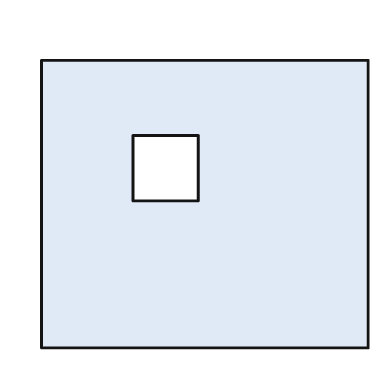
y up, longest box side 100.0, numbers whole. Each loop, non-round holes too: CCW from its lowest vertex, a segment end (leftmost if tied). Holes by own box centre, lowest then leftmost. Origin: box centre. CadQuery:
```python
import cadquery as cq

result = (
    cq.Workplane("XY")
    .moveTo(-50.0, -44.0)
    .lineTo(50.0, -44.0)
    .lineTo(50.0, 44.0)
    .lineTo(-50.0, 44.0)
    .close()
    .moveTo(-22.0, 1.0)
    .lineTo(-2.0, 1.0)
    .lineTo(-2.0, 21.0)
    .lineTo(-22.0, 21.0)
    .close()
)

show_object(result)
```